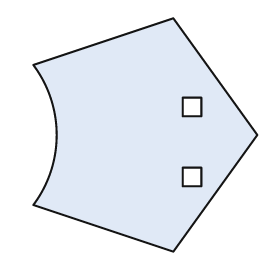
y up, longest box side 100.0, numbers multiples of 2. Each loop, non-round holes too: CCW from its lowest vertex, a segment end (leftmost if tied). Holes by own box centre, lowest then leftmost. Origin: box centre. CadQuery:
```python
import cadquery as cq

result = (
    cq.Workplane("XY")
    .moveTo(12.0, -50.0)
    .lineTo(48.0, 0.0)
    .lineTo(12.0, 50.0)
    .lineTo(-48.0, 30.0)
    .threePointArc((-38.0, 0.0), (-48.0, -30.0))
    .close()
    .moveTo(16.0, -22.0)
    .lineTo(24.0, -22.0)
    .lineTo(24.0, -14.0)
    .lineTo(16.0, -14.0)
    .close()
    .moveTo(16.0, 8.0)
    .lineTo(24.0, 8.0)
    .lineTo(24.0, 16.0)
    .lineTo(16.0, 16.0)
    .close()
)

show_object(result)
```